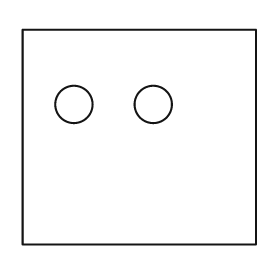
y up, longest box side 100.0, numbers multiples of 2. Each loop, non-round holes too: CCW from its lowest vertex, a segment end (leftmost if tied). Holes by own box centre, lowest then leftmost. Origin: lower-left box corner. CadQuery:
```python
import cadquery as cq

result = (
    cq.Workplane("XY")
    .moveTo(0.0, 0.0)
    .lineTo(100.0, 0.0)
    .lineTo(100.0, 92.0)
    .lineTo(0.0, 92.0)
    .close()
    .moveTo(22.0, 60.0)
    .circle(8.0)
    .moveTo(56.0, 60.0)
    .circle(8.0)
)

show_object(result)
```